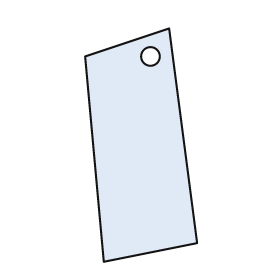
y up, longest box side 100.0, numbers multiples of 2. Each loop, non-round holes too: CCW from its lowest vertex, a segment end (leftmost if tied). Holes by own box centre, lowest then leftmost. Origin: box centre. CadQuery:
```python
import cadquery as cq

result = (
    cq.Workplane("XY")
    .moveTo(-16.0, -50.0)
    .lineTo(24.0, -42.0)
    .lineTo(12.0, 50.0)
    .lineTo(-24.0, 38.0)
    .close()
    .moveTo(4.0, 38.0)
    .circle(4.0)
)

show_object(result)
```